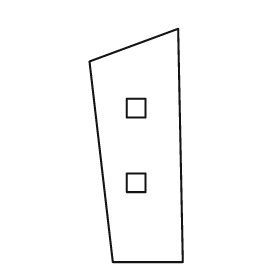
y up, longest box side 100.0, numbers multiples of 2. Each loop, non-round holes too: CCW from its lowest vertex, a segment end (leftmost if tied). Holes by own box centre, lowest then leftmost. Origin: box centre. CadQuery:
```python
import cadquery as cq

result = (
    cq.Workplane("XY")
    .moveTo(-10.0, -50.0)
    .lineTo(20.0, -50.0)
    .lineTo(18.0, 50.0)
    .lineTo(-20.0, 36.0)
    .close()
    .moveTo(-4.0, -20.0)
    .lineTo(4.0, -20.0)
    .lineTo(4.0, -12.0)
    .lineTo(-4.0, -12.0)
    .close()
    .moveTo(-4.0, 12.0)
    .lineTo(4.0, 12.0)
    .lineTo(4.0, 20.0)
    .lineTo(-4.0, 20.0)
    .close()
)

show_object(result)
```